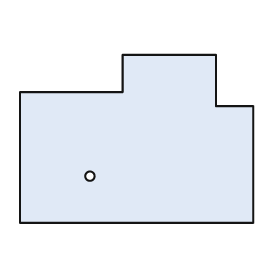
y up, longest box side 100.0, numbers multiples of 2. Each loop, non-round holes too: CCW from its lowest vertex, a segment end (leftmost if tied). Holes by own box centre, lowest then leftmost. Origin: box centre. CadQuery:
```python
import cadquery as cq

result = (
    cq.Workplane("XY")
    .moveTo(-50.0, -36.0)
    .lineTo(50.0, -36.0)
    .lineTo(50.0, 14.0)
    .lineTo(34.0, 14.0)
    .lineTo(34.0, 36.0)
    .lineTo(-6.0, 36.0)
    .lineTo(-6.0, 20.0)
    .lineTo(-50.0, 20.0)
    .close()
    .moveTo(-20.0, -16.0)
    .circle(2.0)
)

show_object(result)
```